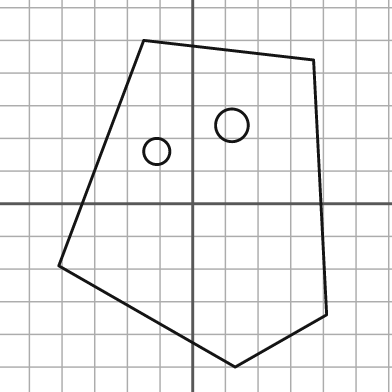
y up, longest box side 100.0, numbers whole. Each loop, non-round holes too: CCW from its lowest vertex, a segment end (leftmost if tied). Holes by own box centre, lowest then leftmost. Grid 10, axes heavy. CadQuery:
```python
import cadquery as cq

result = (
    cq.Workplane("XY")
    .moveTo(13.0, -50.0)
    .lineTo(41.0, -34.0)
    .lineTo(37.0, 44.0)
    .lineTo(-15.0, 50.0)
    .lineTo(-41.0, -19.0)
    .close()
    .moveTo(-11.0, 16.0)
    .circle(4.0)
    .moveTo(12.0, 24.0)
    .circle(5.0)
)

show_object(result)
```